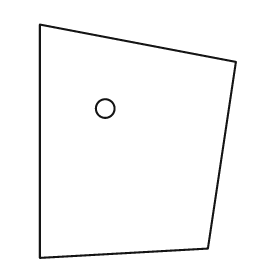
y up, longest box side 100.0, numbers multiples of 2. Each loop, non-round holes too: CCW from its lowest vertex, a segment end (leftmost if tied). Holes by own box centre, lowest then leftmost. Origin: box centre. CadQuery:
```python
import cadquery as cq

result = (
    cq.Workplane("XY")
    .moveTo(-42.0, -50.0)
    .lineTo(30.0, -46.0)
    .lineTo(42.0, 34.0)
    .lineTo(-42.0, 50.0)
    .close()
    .moveTo(-14.0, 14.0)
    .circle(4.0)
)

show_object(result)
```